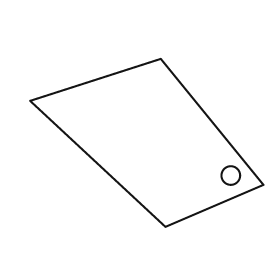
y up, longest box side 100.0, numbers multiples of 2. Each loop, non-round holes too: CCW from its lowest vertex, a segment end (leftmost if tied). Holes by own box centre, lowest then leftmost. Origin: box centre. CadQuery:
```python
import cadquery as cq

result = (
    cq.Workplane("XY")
    .moveTo(8.0, -36.0)
    .lineTo(50.0, -18.0)
    .lineTo(6.0, 36.0)
    .lineTo(-50.0, 18.0)
    .close()
    .moveTo(36.0, -14.0)
    .circle(4.0)
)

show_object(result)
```